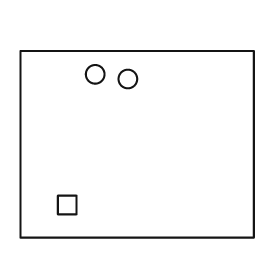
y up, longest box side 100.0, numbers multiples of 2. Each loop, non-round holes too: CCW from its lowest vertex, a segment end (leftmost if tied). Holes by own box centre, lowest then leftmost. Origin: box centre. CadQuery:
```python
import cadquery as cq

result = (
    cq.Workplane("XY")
    .moveTo(-50.0, -40.0)
    .lineTo(50.0, -40.0)
    .lineTo(50.0, 40.0)
    .lineTo(-50.0, 40.0)
    .close()
    .moveTo(-34.0, -30.0)
    .lineTo(-26.0, -30.0)
    .lineTo(-26.0, -22.0)
    .lineTo(-34.0, -22.0)
    .close()
    .moveTo(-4.0, 28.0)
    .circle(4.0)
    .moveTo(-18.0, 30.0)
    .circle(4.0)
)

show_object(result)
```